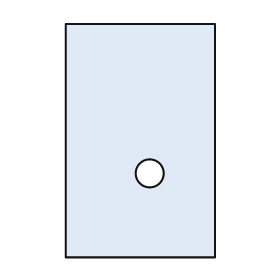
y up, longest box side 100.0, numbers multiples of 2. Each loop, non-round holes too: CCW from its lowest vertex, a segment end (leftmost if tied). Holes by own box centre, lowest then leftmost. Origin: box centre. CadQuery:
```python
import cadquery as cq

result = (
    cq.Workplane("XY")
    .moveTo(-32.0, -50.0)
    .lineTo(32.0, -50.0)
    .lineTo(32.0, 50.0)
    .lineTo(-32.0, 50.0)
    .close()
    .moveTo(4.0, -14.0)
    .circle(6.0)
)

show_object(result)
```